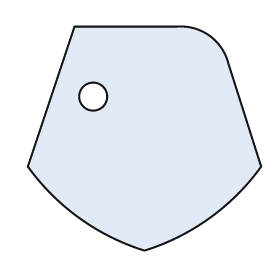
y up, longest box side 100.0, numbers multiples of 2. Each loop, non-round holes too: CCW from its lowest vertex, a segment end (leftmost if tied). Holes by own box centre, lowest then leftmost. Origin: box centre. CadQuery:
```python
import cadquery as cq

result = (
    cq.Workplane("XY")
    .moveTo(0.0, -48.0)
    .threePointArc((28.0, -34.0), (50.0, -12.0))
    .lineTo(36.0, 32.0)
    .threePointArc((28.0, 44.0), (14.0, 48.0))
    .lineTo(-30.0, 48.0)
    .lineTo(-50.0, -12.0)
    .threePointArc((-28.0, -34.0), (0.0, -48.0))
    .close()
    .moveTo(-22.0, 18.0)
    .circle(6.0)
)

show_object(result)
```